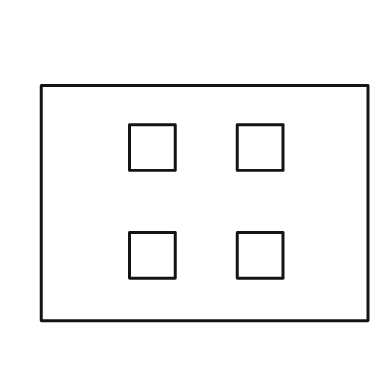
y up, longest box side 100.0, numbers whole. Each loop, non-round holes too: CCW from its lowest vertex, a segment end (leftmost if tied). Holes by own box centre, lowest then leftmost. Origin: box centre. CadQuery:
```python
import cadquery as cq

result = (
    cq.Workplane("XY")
    .moveTo(-50.0, -36.0)
    .lineTo(50.0, -36.0)
    .lineTo(50.0, 36.0)
    .lineTo(-50.0, 36.0)
    .close()
    .moveTo(-23.0, -23.0)
    .lineTo(-9.0, -23.0)
    .lineTo(-9.0, -9.0)
    .lineTo(-23.0, -9.0)
    .close()
    .moveTo(10.0, -23.0)
    .lineTo(24.0, -23.0)
    .lineTo(24.0, -9.0)
    .lineTo(10.0, -9.0)
    .close()
    .moveTo(-23.0, 10.0)
    .lineTo(-9.0, 10.0)
    .lineTo(-9.0, 24.0)
    .lineTo(-23.0, 24.0)
    .close()
    .moveTo(10.0, 10.0)
    .lineTo(24.0, 10.0)
    .lineTo(24.0, 24.0)
    .lineTo(10.0, 24.0)
    .close()
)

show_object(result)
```